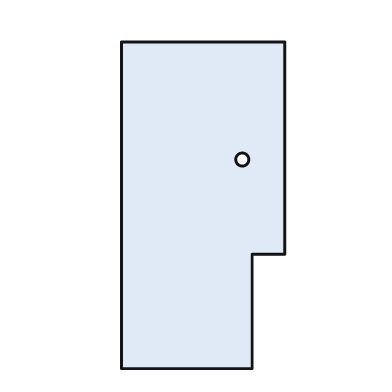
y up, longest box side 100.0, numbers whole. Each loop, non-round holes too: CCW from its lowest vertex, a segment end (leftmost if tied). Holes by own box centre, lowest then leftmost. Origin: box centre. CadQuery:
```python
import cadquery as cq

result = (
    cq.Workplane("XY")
    .moveTo(-25.0, -50.0)
    .lineTo(15.0, -50.0)
    .lineTo(15.0, -15.0)
    .lineTo(25.0, -15.0)
    .lineTo(25.0, 50.0)
    .lineTo(-25.0, 50.0)
    .close()
    .moveTo(12.0, 14.0)
    .circle(2.0)
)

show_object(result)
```